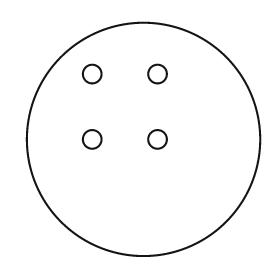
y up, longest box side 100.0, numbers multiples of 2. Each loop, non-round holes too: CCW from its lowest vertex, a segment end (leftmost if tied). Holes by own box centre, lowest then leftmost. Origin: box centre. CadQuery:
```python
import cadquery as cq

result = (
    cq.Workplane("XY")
    .moveTo(0.0, 0.0)
    .circle(50.0)
    .moveTo(-22.0, 0.0)
    .circle(4.0)
    .moveTo(6.0, 0.0)
    .circle(4.0)
    .moveTo(-22.0, 28.0)
    .circle(4.0)
    .moveTo(6.0, 28.0)
    .circle(4.0)
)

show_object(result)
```